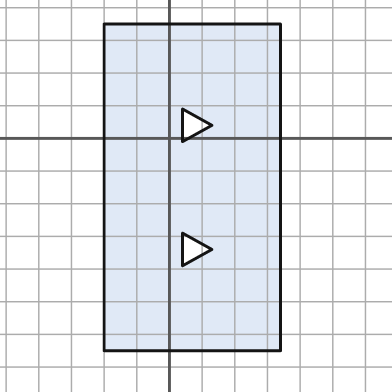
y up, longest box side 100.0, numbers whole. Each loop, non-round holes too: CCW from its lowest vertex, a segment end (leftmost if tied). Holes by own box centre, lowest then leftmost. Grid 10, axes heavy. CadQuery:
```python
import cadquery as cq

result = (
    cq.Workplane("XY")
    .moveTo(-20.0, -65.0)
    .lineTo(34.0, -65.0)
    .lineTo(34.0, 35.0)
    .lineTo(-20.0, 35.0)
    .close()
    .moveTo(4.0, -39.0)
    .lineTo(13.0, -34.0)
    .lineTo(4.0, -29.0)
    .close()
    .moveTo(4.0, -1.0)
    .lineTo(13.0, 4.0)
    .lineTo(4.0, 9.0)
    .close()
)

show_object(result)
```